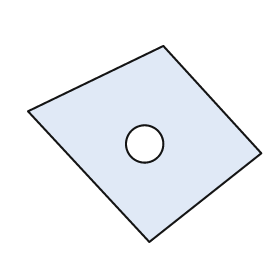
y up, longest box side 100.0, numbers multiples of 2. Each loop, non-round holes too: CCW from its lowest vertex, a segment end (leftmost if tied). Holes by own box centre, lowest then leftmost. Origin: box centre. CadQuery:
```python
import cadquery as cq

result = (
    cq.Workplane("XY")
    .moveTo(2.0, -42.0)
    .lineTo(50.0, -4.0)
    .lineTo(8.0, 42.0)
    .lineTo(-50.0, 14.0)
    .close()
    .moveTo(0.0, 0.0)
    .circle(8.0)
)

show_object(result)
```